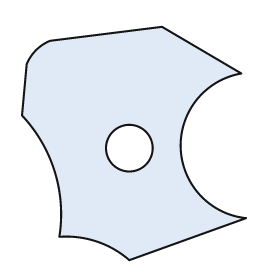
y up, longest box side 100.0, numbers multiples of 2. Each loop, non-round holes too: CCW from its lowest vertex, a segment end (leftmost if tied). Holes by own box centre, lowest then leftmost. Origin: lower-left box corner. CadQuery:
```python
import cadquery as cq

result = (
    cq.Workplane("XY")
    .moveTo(46.0, 0.0)
    .lineTo(96.0, 18.0)
    .threePointArc((68.0, 48.0), (94.0, 80.0))
    .lineTo(60.0, 100.0)
    .lineTo(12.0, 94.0)
    .threePointArc((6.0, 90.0), (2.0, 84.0))
    .lineTo(0.0, 62.0)
    .threePointArc((14.0, 38.0), (16.0, 10.0))
    .threePointArc((32.0, 8.0), (46.0, 0.0))
    .close()
    .moveTo(46.0, 48.0)
    .circle(10.0)
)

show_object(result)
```